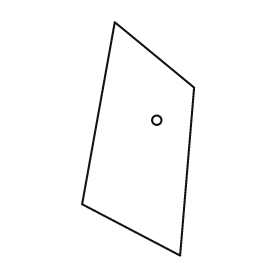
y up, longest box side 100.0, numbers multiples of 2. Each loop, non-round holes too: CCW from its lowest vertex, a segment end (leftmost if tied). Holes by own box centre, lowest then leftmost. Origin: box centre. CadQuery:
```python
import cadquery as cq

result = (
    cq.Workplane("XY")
    .moveTo(18.0, -50.0)
    .lineTo(24.0, 22.0)
    .lineTo(-10.0, 50.0)
    .lineTo(-24.0, -28.0)
    .close()
    .moveTo(8.0, 8.0)
    .circle(2.0)
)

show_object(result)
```